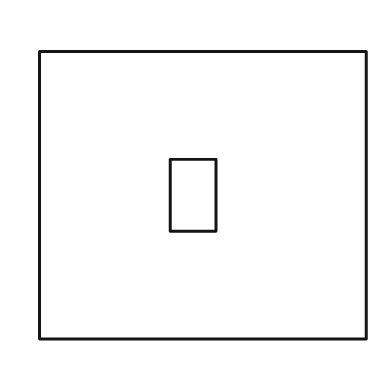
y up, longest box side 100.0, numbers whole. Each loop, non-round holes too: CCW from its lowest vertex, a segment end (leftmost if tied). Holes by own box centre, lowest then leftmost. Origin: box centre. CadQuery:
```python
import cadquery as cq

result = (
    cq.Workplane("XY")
    .moveTo(-50.0, -44.0)
    .lineTo(50.0, -44.0)
    .lineTo(50.0, 44.0)
    .lineTo(-50.0, 44.0)
    .close()
    .moveTo(-10.0, -11.0)
    .lineTo(4.0, -11.0)
    .lineTo(4.0, 11.0)
    .lineTo(-10.0, 11.0)
    .close()
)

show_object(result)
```